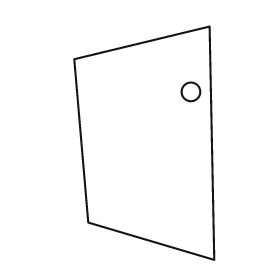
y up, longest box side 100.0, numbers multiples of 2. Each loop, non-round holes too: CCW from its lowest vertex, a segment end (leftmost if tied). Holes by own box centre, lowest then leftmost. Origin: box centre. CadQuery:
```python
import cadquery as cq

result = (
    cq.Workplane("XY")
    .moveTo(30.0, -50.0)
    .lineTo(28.0, 50.0)
    .lineTo(-30.0, 36.0)
    .lineTo(-24.0, -34.0)
    .close()
    .moveTo(20.0, 22.0)
    .circle(4.0)
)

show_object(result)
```